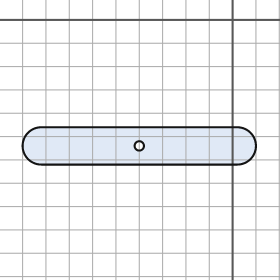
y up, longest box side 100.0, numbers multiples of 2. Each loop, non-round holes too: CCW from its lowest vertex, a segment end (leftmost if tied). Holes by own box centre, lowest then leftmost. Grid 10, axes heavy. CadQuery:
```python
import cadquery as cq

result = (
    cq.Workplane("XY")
    .moveTo(-82.0, -62.0)
    .lineTo(2.0, -62.0)
    .threePointArc((10.0, -54.0), (2.0, -46.0))
    .lineTo(-82.0, -46.0)
    .threePointArc((-90.0, -54.0), (-82.0, -62.0))
    .close()
    .moveTo(-40.0, -54.0)
    .circle(2.0)
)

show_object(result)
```